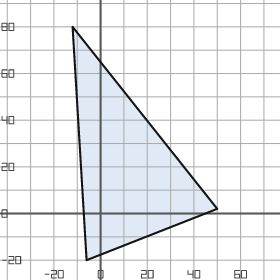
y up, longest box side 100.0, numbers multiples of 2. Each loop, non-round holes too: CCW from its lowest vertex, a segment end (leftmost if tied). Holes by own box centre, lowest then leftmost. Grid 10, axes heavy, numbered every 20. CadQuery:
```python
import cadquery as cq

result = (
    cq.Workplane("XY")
    .moveTo(-6.0, -20.0)
    .lineTo(50.0, 2.0)
    .lineTo(-12.0, 80.0)
    .close()
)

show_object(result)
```